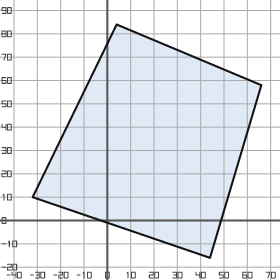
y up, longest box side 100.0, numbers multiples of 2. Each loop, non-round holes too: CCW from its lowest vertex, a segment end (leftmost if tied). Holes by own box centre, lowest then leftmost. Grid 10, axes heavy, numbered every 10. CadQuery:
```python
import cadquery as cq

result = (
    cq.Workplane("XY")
    .moveTo(44.0, -16.0)
    .lineTo(66.0, 58.0)
    .lineTo(4.0, 84.0)
    .lineTo(-32.0, 10.0)
    .close()
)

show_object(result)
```